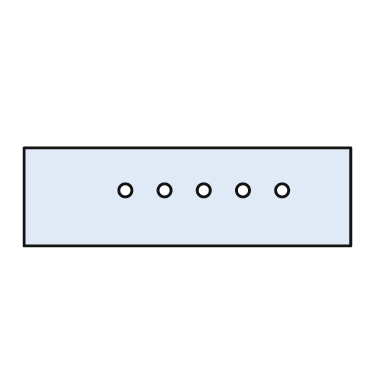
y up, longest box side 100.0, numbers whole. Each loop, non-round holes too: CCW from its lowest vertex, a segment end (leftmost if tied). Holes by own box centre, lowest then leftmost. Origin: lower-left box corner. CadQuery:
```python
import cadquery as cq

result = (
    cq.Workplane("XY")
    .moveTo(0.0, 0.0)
    .lineTo(100.0, 0.0)
    .lineTo(100.0, 30.0)
    .lineTo(0.0, 30.0)
    .close()
    .moveTo(31.0, 17.0)
    .circle(2.0)
    .moveTo(43.0, 17.0)
    .circle(2.0)
    .moveTo(55.0, 17.0)
    .circle(2.0)
    .moveTo(67.0, 17.0)
    .circle(2.0)
    .moveTo(79.0, 17.0)
    .circle(2.0)
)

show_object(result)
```